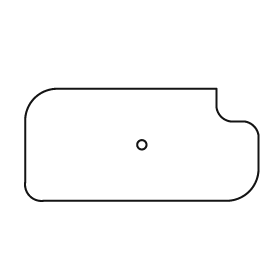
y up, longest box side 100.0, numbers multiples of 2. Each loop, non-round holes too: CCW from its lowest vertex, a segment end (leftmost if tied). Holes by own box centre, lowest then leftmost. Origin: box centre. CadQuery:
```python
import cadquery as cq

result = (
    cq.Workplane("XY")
    .moveTo(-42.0, -24.0)
    .lineTo(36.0, -24.0)
    .threePointArc((46.0, -20.0), (50.0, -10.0))
    .lineTo(50.0, 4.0)
    .threePointArc((48.0, 8.0), (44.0, 10.0))
    .lineTo(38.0, 10.0)
    .threePointArc((34.0, 12.0), (32.0, 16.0))
    .lineTo(32.0, 24.0)
    .lineTo(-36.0, 24.0)
    .threePointArc((-46.0, 20.0), (-50.0, 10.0))
    .lineTo(-50.0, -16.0)
    .threePointArc((-48.0, -22.0), (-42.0, -24.0))
    .close()
    .moveTo(0.0, 0.0)
    .circle(2.0)
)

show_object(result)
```